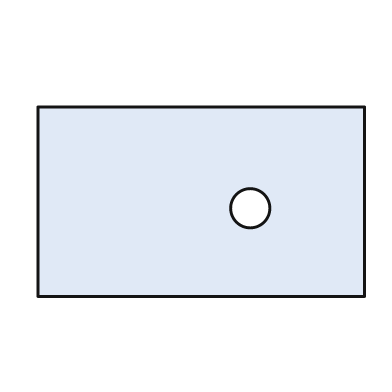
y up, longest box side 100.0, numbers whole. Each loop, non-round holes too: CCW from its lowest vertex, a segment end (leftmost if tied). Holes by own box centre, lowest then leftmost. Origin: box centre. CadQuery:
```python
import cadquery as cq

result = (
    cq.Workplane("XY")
    .moveTo(-50.0, -29.0)
    .lineTo(50.0, -29.0)
    .lineTo(50.0, 29.0)
    .lineTo(-50.0, 29.0)
    .close()
    .moveTo(15.0, -2.0)
    .circle(6.0)
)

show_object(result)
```